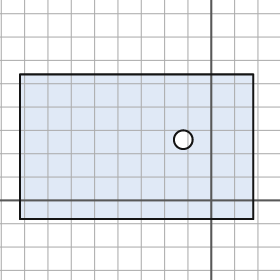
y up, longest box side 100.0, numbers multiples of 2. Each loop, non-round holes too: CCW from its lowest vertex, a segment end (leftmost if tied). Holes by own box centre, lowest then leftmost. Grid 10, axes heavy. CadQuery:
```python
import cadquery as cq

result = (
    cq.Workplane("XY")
    .moveTo(-82.0, -8.0)
    .lineTo(18.0, -8.0)
    .lineTo(18.0, 54.0)
    .lineTo(-82.0, 54.0)
    .close()
    .moveTo(-12.0, 26.0)
    .circle(4.0)
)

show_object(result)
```